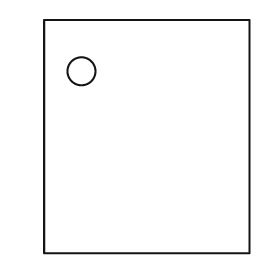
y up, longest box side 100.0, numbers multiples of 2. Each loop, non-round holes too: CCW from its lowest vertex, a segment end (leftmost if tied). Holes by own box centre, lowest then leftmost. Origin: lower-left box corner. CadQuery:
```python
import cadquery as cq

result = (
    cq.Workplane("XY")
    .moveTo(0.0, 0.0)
    .lineTo(88.0, 0.0)
    .lineTo(88.0, 100.0)
    .lineTo(0.0, 100.0)
    .close()
    .moveTo(16.0, 78.0)
    .circle(6.0)
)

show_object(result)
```